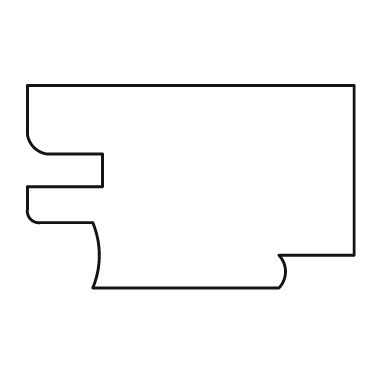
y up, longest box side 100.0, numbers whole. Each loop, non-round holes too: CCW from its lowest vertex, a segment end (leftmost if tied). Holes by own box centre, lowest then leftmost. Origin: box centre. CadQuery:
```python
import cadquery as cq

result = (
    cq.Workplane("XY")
    .moveTo(-30.0, -31.0)
    .lineTo(27.0, -31.0)
    .threePointArc((29.0, -26.0), (27.0, -21.0))
    .lineTo(50.0, -21.0)
    .lineTo(50.0, 31.0)
    .lineTo(-50.0, 31.0)
    .lineTo(-50.0, 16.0)
    .threePointArc((-48.0, 12.0), (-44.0, 10.0))
    .lineTo(-27.0, 10.0)
    .lineTo(-27.0, 0.0)
    .lineTo(-50.0, 0.0)
    .lineTo(-50.0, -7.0)
    .threePointArc((-49.0, -10.0), (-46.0, -11.0))
    .lineTo(-30.0, -11.0)
    .threePointArc((-28.0, -21.0), (-30.0, -31.0))
    .close()
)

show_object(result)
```